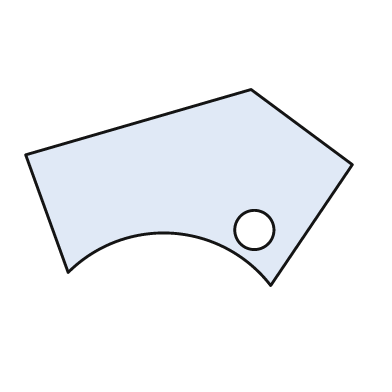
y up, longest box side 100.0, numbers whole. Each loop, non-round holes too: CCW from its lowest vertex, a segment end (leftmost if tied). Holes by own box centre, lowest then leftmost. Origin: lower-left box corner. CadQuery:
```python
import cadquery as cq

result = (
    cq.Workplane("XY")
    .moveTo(75.0, 0.0)
    .lineTo(100.0, 37.0)
    .lineTo(69.0, 60.0)
    .lineTo(0.0, 40.0)
    .lineTo(13.0, 4.0)
    .threePointArc((45.0, 16.0), (75.0, 0.0))
    .close()
    .moveTo(70.0, 17.0)
    .circle(6.0)
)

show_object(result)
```